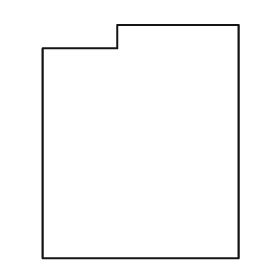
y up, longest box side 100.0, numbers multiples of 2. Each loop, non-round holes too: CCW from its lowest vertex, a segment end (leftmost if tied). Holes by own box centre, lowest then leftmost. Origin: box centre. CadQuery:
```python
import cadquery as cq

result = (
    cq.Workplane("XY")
    .moveTo(-42.0, -50.0)
    .lineTo(42.0, -50.0)
    .lineTo(42.0, 50.0)
    .lineTo(-10.0, 50.0)
    .lineTo(-10.0, 40.0)
    .lineTo(-42.0, 40.0)
    .close()
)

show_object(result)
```